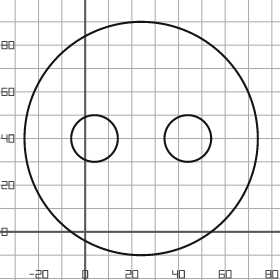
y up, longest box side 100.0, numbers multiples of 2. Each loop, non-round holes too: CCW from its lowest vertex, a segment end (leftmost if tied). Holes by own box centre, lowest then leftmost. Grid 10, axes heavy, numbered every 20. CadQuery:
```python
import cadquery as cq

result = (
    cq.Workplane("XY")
    .moveTo(24.0, 40.0)
    .circle(50.0)
    .moveTo(4.0, 40.0)
    .circle(10.0)
    .moveTo(44.0, 40.0)
    .circle(10.0)
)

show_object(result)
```